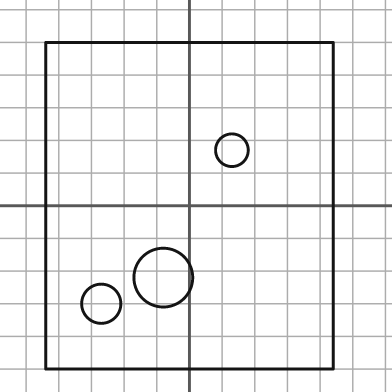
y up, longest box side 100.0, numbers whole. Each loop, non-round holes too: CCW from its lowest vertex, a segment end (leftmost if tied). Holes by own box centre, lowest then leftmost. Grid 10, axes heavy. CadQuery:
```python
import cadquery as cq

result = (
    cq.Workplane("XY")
    .moveTo(-44.0, -50.0)
    .lineTo(44.0, -50.0)
    .lineTo(44.0, 50.0)
    .lineTo(-44.0, 50.0)
    .close()
    .moveTo(-27.0, -30.0)
    .circle(6.0)
    .moveTo(-8.0, -22.0)
    .circle(9.0)
    .moveTo(13.0, 17.0)
    .circle(5.0)
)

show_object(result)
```